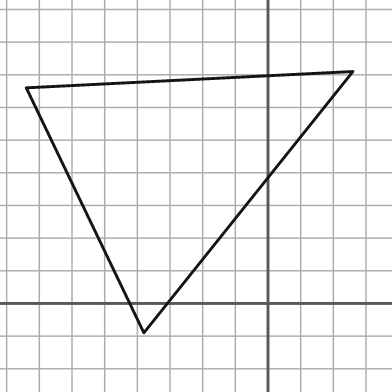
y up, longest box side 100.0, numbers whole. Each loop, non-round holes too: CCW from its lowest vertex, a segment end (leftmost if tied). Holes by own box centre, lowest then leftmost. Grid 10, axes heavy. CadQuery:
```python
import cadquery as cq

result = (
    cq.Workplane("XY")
    .moveTo(-38.0, -9.0)
    .lineTo(26.0, 71.0)
    .lineTo(-74.0, 66.0)
    .close()
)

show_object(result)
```